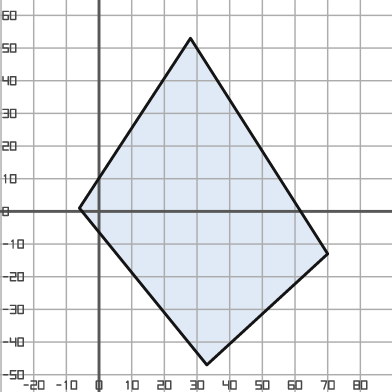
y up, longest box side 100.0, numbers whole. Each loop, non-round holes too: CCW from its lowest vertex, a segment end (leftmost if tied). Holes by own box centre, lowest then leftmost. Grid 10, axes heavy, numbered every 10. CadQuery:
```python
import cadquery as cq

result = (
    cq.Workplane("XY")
    .moveTo(33.0, -47.0)
    .lineTo(70.0, -13.0)
    .lineTo(28.0, 53.0)
    .lineTo(-6.0, 1.0)
    .close()
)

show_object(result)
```